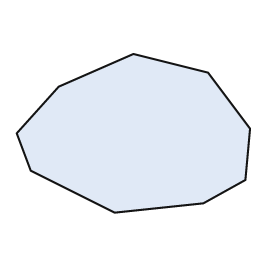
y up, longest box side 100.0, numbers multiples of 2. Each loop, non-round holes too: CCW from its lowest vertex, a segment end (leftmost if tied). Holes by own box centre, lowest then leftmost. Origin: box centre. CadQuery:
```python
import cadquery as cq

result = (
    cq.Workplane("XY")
    .moveTo(-8.0, -34.0)
    .lineTo(30.0, -30.0)
    .lineTo(48.0, -20.0)
    .lineTo(50.0, 2.0)
    .lineTo(32.0, 26.0)
    .lineTo(0.0, 34.0)
    .lineTo(-32.0, 20.0)
    .lineTo(-50.0, 0.0)
    .lineTo(-44.0, -16.0)
    .close()
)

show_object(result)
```